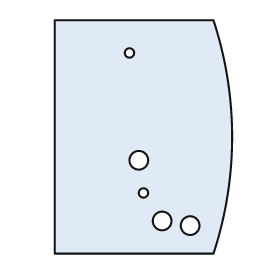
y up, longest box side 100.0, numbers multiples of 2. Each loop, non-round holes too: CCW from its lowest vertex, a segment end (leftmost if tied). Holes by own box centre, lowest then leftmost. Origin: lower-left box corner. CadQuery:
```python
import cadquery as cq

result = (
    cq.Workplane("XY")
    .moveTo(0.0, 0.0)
    .lineTo(68.0, 0.0)
    .threePointArc((76.0, 50.0), (68.0, 100.0))
    .lineTo(0.0, 100.0)
    .close()
    .moveTo(58.0, 12.0)
    .circle(4.0)
    .moveTo(46.0, 14.0)
    .circle(4.0)
    .moveTo(38.0, 26.0)
    .circle(2.0)
    .moveTo(36.0, 40.0)
    .circle(4.0)
    .moveTo(32.0, 86.0)
    .circle(2.0)
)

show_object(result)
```